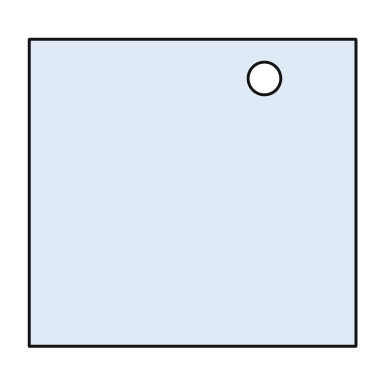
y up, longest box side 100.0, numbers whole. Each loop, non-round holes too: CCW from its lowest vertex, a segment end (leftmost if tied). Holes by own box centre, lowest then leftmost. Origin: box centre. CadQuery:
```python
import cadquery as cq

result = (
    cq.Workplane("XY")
    .moveTo(-50.0, -47.0)
    .lineTo(50.0, -47.0)
    .lineTo(50.0, 47.0)
    .lineTo(-50.0, 47.0)
    .close()
    .moveTo(22.0, 35.0)
    .circle(5.0)
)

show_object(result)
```